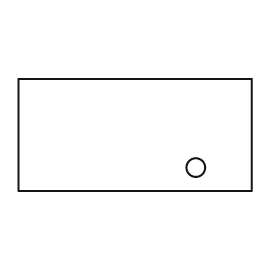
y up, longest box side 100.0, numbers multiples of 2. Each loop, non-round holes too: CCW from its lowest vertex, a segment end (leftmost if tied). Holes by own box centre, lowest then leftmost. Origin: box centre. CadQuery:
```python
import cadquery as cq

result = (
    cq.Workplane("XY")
    .moveTo(-50.0, -24.0)
    .lineTo(50.0, -24.0)
    .lineTo(50.0, 24.0)
    .lineTo(-50.0, 24.0)
    .close()
    .moveTo(26.0, -14.0)
    .circle(4.0)
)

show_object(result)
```